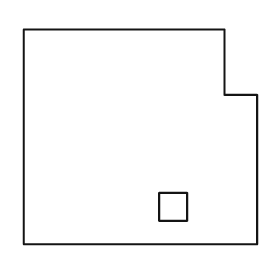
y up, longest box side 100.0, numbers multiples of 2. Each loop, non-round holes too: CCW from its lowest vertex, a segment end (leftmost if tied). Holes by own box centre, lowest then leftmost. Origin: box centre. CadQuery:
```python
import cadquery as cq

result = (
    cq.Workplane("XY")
    .moveTo(-50.0, -46.0)
    .lineTo(50.0, -46.0)
    .lineTo(50.0, 18.0)
    .lineTo(36.0, 18.0)
    .lineTo(36.0, 46.0)
    .lineTo(-50.0, 46.0)
    .close()
    .moveTo(8.0, -36.0)
    .lineTo(20.0, -36.0)
    .lineTo(20.0, -24.0)
    .lineTo(8.0, -24.0)
    .close()
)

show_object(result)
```